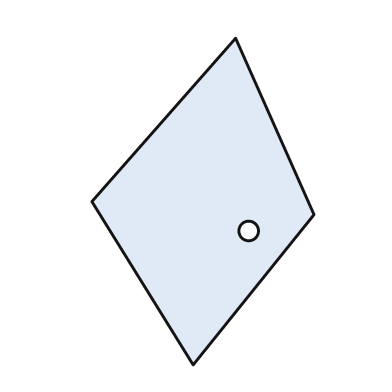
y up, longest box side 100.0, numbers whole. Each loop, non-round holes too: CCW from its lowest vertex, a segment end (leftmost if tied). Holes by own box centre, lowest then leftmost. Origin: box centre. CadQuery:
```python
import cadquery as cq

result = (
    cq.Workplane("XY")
    .moveTo(-3.0, -50.0)
    .lineTo(34.0, -4.0)
    .lineTo(10.0, 50.0)
    .lineTo(-34.0, 0.0)
    .close()
    .moveTo(14.0, -9.0)
    .circle(3.0)
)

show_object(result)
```